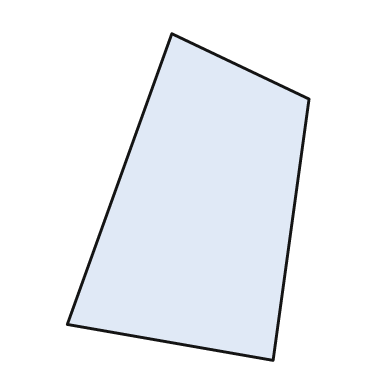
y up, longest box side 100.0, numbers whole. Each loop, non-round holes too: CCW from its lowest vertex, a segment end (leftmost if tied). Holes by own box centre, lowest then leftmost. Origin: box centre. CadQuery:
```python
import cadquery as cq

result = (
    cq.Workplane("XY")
    .moveTo(26.0, -50.0)
    .lineTo(37.0, 30.0)
    .lineTo(-5.0, 50.0)
    .lineTo(-37.0, -39.0)
    .close()
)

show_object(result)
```